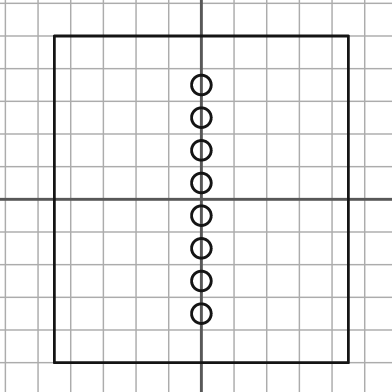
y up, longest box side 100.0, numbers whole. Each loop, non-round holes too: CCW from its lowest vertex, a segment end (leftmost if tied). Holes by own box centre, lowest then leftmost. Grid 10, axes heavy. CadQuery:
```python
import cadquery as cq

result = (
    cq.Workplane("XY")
    .moveTo(-45.0, -50.0)
    .lineTo(45.0, -50.0)
    .lineTo(45.0, 50.0)
    .lineTo(-45.0, 50.0)
    .close()
    .moveTo(0.0, -35.0)
    .circle(3.0)
    .moveTo(0.0, -25.0)
    .circle(3.0)
    .moveTo(0.0, -15.0)
    .circle(3.0)
    .moveTo(0.0, -5.0)
    .circle(3.0)
    .moveTo(0.0, 5.0)
    .circle(3.0)
    .moveTo(0.0, 15.0)
    .circle(3.0)
    .moveTo(0.0, 25.0)
    .circle(3.0)
    .moveTo(0.0, 35.0)
    .circle(3.0)
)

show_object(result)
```